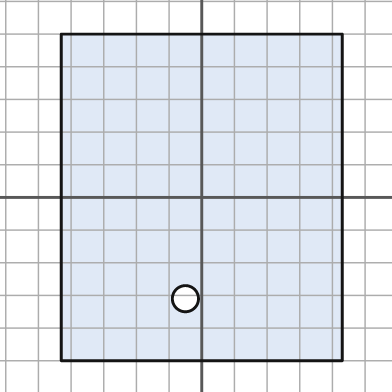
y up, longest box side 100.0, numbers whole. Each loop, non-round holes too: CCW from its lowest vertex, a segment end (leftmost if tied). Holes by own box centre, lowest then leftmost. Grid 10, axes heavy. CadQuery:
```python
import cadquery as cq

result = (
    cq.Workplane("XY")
    .moveTo(-43.0, -50.0)
    .lineTo(43.0, -50.0)
    .lineTo(43.0, 50.0)
    .lineTo(-43.0, 50.0)
    .close()
    .moveTo(-5.0, -31.0)
    .circle(4.0)
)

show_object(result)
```